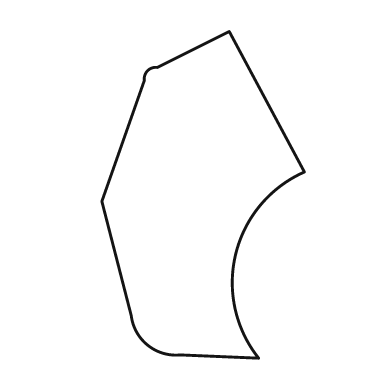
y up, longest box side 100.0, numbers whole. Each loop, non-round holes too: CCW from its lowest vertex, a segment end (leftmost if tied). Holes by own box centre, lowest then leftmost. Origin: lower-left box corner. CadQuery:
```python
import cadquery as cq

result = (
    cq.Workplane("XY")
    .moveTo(48.0, 0.0)
    .threePointArc((41.0, 32.0), (62.0, 57.0))
    .lineTo(39.0, 100.0)
    .lineTo(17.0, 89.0)
    .threePointArc((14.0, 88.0), (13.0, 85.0))
    .lineTo(0.0, 48.0)
    .lineTo(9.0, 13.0)
    .threePointArc((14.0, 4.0), (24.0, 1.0))
    .close()
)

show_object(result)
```